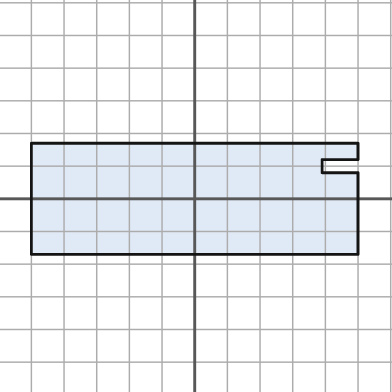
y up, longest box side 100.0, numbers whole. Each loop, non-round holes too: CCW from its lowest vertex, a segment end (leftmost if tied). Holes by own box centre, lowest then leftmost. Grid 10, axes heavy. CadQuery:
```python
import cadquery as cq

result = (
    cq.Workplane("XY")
    .moveTo(-50.0, -17.0)
    .lineTo(50.0, -17.0)
    .lineTo(50.0, 8.0)
    .lineTo(39.0, 8.0)
    .lineTo(39.0, 12.0)
    .lineTo(50.0, 12.0)
    .lineTo(50.0, 17.0)
    .lineTo(-50.0, 17.0)
    .close()
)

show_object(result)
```